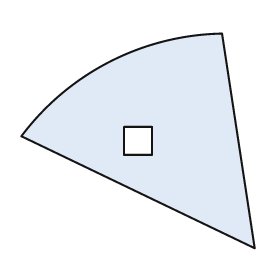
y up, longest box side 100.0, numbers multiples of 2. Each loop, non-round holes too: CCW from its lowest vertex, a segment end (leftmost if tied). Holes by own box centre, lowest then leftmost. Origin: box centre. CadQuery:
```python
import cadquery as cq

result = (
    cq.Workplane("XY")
    .moveTo(50.0, -46.0)
    .lineTo(36.0, 46.0)
    .threePointArc((-12.0, 34.0), (-50.0, 2.0))
    .close()
    .moveTo(-6.0, -6.0)
    .lineTo(6.0, -6.0)
    .lineTo(6.0, 6.0)
    .lineTo(-6.0, 6.0)
    .close()
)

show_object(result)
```